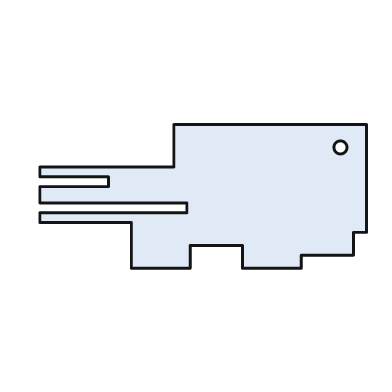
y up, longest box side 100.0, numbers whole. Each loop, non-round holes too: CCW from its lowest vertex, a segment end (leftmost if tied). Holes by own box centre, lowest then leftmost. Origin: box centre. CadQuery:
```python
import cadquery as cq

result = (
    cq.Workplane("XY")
    .moveTo(-22.0, -22.0)
    .lineTo(-4.0, -22.0)
    .lineTo(-4.0, -15.0)
    .lineTo(12.0, -15.0)
    .lineTo(12.0, -22.0)
    .lineTo(30.0, -22.0)
    .lineTo(30.0, -18.0)
    .lineTo(46.0, -18.0)
    .lineTo(46.0, -11.0)
    .lineTo(50.0, -11.0)
    .lineTo(50.0, 22.0)
    .lineTo(-9.0, 22.0)
    .lineTo(-9.0, 9.0)
    .lineTo(-50.0, 9.0)
    .lineTo(-50.0, 6.0)
    .lineTo(-29.0, 6.0)
    .lineTo(-29.0, 3.0)
    .lineTo(-50.0, 3.0)
    .lineTo(-50.0, -2.0)
    .lineTo(-5.0, -2.0)
    .lineTo(-5.0, -5.0)
    .lineTo(-50.0, -5.0)
    .lineTo(-50.0, -8.0)
    .lineTo(-22.0, -8.0)
    .close()
    .moveTo(42.0, 15.0)
    .circle(2.0)
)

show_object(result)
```